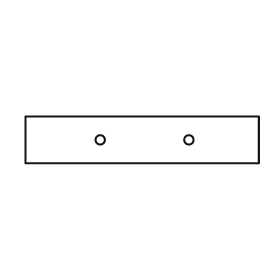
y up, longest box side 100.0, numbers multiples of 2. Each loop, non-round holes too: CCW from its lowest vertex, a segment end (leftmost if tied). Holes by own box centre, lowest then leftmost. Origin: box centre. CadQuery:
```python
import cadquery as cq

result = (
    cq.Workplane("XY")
    .moveTo(-50.0, -10.0)
    .lineTo(50.0, -10.0)
    .lineTo(50.0, 10.0)
    .lineTo(-50.0, 10.0)
    .close()
    .moveTo(-18.0, 0.0)
    .circle(2.0)
    .moveTo(20.0, 0.0)
    .circle(2.0)
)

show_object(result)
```